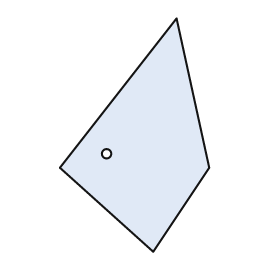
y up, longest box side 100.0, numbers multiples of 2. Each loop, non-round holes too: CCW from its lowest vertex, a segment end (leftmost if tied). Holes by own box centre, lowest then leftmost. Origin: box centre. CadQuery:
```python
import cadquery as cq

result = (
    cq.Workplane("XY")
    .moveTo(8.0, -50.0)
    .lineTo(32.0, -14.0)
    .lineTo(18.0, 50.0)
    .lineTo(-32.0, -14.0)
    .close()
    .moveTo(-12.0, -8.0)
    .circle(2.0)
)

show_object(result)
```